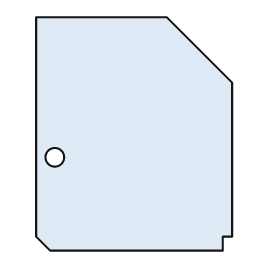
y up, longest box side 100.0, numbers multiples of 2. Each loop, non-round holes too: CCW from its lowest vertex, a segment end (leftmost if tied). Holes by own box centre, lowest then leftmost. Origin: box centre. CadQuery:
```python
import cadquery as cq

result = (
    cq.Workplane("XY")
    .moveTo(-36.0, -50.0)
    .lineTo(38.0, -50.0)
    .lineTo(38.0, -44.0)
    .lineTo(42.0, -44.0)
    .lineTo(42.0, 22.0)
    .lineTo(14.0, 50.0)
    .lineTo(-42.0, 50.0)
    .lineTo(-42.0, -44.0)
    .close()
    .moveTo(-34.0, -10.0)
    .circle(4.0)
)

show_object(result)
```